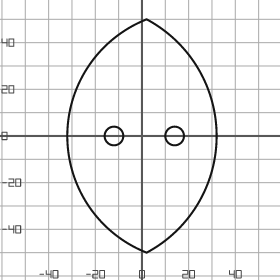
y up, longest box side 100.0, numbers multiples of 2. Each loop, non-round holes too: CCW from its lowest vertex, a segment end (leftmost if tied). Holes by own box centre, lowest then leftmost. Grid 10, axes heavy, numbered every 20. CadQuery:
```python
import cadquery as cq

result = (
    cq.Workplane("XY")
    .moveTo(2.0, -50.0)
    .threePointArc((32.0, 0.0), (2.0, 50.0))
    .threePointArc((-32.0, 0.0), (2.0, -50.0))
    .close()
    .moveTo(-12.0, 0.0)
    .circle(4.0)
    .moveTo(14.0, 0.0)
    .circle(4.0)
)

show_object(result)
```